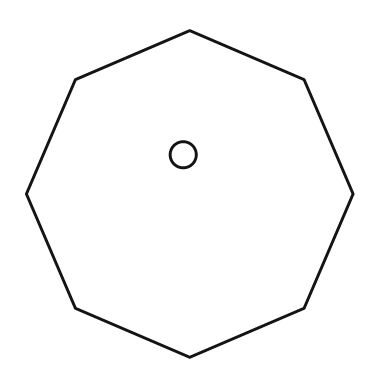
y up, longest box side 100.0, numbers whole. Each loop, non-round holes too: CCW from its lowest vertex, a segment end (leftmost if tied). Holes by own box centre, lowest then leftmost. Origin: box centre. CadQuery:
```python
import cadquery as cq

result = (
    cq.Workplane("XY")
    .moveTo(0.0, -50.0)
    .lineTo(35.0, -35.0)
    .lineTo(50.0, 0.0)
    .lineTo(35.0, 35.0)
    .lineTo(0.0, 50.0)
    .lineTo(-35.0, 35.0)
    .lineTo(-50.0, 0.0)
    .lineTo(-35.0, -35.0)
    .close()
    .moveTo(-2.0, 12.0)
    .circle(4.0)
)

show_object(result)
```